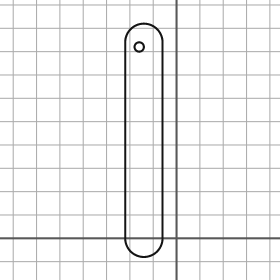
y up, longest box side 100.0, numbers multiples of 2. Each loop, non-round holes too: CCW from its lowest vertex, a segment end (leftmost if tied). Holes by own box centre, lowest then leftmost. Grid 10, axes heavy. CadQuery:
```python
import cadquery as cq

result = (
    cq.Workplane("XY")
    .moveTo(-22.0, 0.0)
    .threePointArc((-14.0, -8.0), (-6.0, 0.0))
    .lineTo(-6.0, 84.0)
    .threePointArc((-14.0, 92.0), (-22.0, 84.0))
    .close()
    .moveTo(-16.0, 82.0)
    .circle(2.0)
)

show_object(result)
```